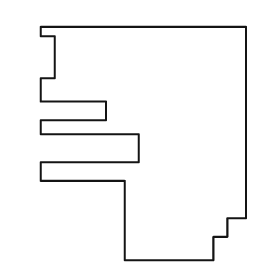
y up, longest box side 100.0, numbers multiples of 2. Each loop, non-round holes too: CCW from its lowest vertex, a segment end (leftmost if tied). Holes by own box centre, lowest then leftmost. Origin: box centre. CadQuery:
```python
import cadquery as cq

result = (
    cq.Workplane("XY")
    .moveTo(-8.0, -50.0)
    .lineTo(30.0, -50.0)
    .lineTo(30.0, -40.0)
    .lineTo(36.0, -40.0)
    .lineTo(36.0, -32.0)
    .lineTo(44.0, -32.0)
    .lineTo(44.0, 50.0)
    .lineTo(-44.0, 50.0)
    .lineTo(-44.0, 46.0)
    .lineTo(-38.0, 46.0)
    .lineTo(-38.0, 28.0)
    .lineTo(-44.0, 28.0)
    .lineTo(-44.0, 18.0)
    .lineTo(-16.0, 18.0)
    .lineTo(-16.0, 10.0)
    .lineTo(-44.0, 10.0)
    .lineTo(-44.0, 4.0)
    .lineTo(-2.0, 4.0)
    .lineTo(-2.0, -8.0)
    .lineTo(-44.0, -8.0)
    .lineTo(-44.0, -16.0)
    .lineTo(-8.0, -16.0)
    .close()
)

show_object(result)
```